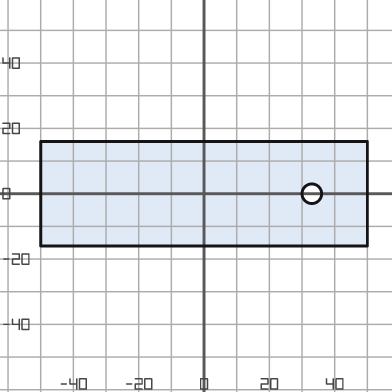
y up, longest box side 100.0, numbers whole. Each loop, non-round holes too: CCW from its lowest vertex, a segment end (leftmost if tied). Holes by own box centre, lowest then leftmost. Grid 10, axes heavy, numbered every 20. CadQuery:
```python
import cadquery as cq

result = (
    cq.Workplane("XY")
    .moveTo(-50.0, -16.0)
    .lineTo(50.0, -16.0)
    .lineTo(50.0, 16.0)
    .lineTo(-50.0, 16.0)
    .close()
    .moveTo(33.0, 0.0)
    .circle(3.0)
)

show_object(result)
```